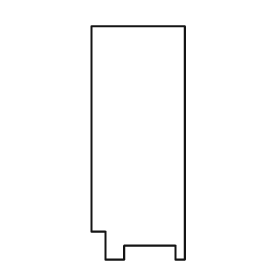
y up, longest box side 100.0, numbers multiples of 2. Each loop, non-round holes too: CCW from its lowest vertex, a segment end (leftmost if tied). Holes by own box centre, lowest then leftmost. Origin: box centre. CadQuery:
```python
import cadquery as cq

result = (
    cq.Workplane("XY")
    .moveTo(-14.0, -50.0)
    .lineTo(-6.0, -50.0)
    .lineTo(-6.0, -44.0)
    .lineTo(16.0, -44.0)
    .lineTo(16.0, -50.0)
    .lineTo(20.0, -50.0)
    .lineTo(20.0, 50.0)
    .lineTo(-20.0, 50.0)
    .lineTo(-20.0, -38.0)
    .lineTo(-14.0, -38.0)
    .close()
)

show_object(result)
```